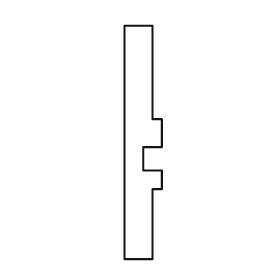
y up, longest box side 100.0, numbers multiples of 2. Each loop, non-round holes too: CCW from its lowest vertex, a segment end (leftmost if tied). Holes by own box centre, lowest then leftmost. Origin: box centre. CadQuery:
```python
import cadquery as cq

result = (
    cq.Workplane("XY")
    .moveTo(-8.0, -50.0)
    .lineTo(4.0, -50.0)
    .lineTo(4.0, -20.0)
    .lineTo(8.0, -20.0)
    .lineTo(8.0, -12.0)
    .lineTo(0.0, -12.0)
    .lineTo(0.0, -2.0)
    .lineTo(8.0, -2.0)
    .lineTo(8.0, 10.0)
    .lineTo(4.0, 10.0)
    .lineTo(4.0, 50.0)
    .lineTo(-8.0, 50.0)
    .close()
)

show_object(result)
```